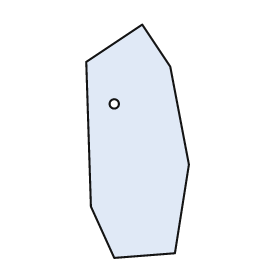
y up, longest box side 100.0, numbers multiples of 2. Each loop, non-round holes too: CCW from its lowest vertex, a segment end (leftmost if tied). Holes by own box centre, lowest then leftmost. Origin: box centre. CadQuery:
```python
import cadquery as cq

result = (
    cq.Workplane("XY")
    .moveTo(-10.0, -50.0)
    .lineTo(16.0, -48.0)
    .lineTo(22.0, -10.0)
    .lineTo(14.0, 32.0)
    .lineTo(2.0, 50.0)
    .lineTo(-22.0, 34.0)
    .lineTo(-20.0, -28.0)
    .close()
    .moveTo(-10.0, 16.0)
    .circle(2.0)
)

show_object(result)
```